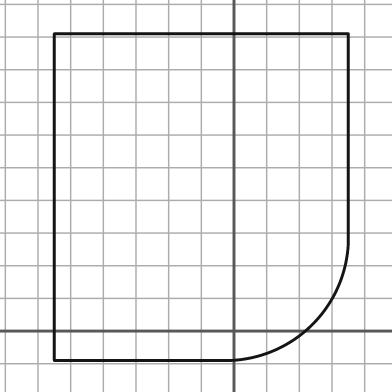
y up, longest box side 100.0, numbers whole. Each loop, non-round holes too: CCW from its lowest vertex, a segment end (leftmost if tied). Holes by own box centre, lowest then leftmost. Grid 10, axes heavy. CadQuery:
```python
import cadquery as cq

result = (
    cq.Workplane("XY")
    .moveTo(-55.0, -9.0)
    .lineTo(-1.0, -9.0)
    .threePointArc((24.0, 2.0), (35.0, 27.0))
    .lineTo(35.0, 91.0)
    .lineTo(-55.0, 91.0)
    .close()
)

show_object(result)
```